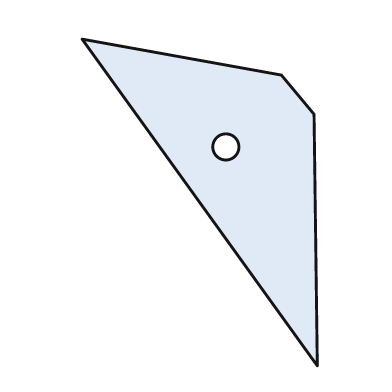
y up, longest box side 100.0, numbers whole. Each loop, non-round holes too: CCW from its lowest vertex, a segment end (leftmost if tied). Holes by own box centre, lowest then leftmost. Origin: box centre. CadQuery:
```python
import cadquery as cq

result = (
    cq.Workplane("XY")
    .moveTo(36.0, -50.0)
    .lineTo(35.0, 27.0)
    .lineTo(25.0, 39.0)
    .lineTo(-36.0, 50.0)
    .close()
    .moveTo(8.0, 17.0)
    .circle(4.0)
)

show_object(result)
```